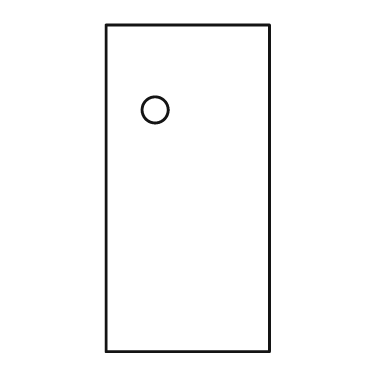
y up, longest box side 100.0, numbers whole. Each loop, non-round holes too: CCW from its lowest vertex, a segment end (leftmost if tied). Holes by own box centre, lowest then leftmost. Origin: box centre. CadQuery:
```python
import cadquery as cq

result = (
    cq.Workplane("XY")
    .moveTo(-25.0, -50.0)
    .lineTo(25.0, -50.0)
    .lineTo(25.0, 50.0)
    .lineTo(-25.0, 50.0)
    .close()
    .moveTo(-10.0, 24.0)
    .circle(4.0)
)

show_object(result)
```